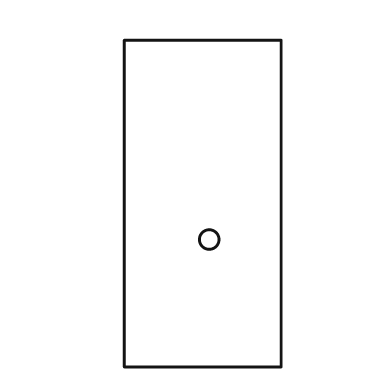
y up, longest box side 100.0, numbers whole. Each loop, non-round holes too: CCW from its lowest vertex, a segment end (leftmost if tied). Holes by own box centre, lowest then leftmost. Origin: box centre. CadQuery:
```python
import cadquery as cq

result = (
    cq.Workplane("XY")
    .moveTo(-24.0, -50.0)
    .lineTo(24.0, -50.0)
    .lineTo(24.0, 50.0)
    .lineTo(-24.0, 50.0)
    .close()
    .moveTo(2.0, -11.0)
    .circle(3.0)
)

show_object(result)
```